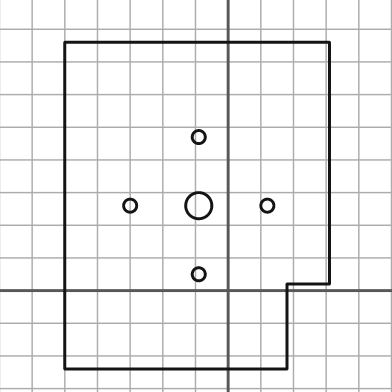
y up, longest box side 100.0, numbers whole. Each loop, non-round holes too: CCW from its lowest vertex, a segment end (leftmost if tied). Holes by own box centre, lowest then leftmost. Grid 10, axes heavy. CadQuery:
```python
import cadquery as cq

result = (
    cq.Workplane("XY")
    .moveTo(-50.0, -24.0)
    .lineTo(18.0, -24.0)
    .lineTo(18.0, 2.0)
    .lineTo(31.0, 2.0)
    .lineTo(31.0, 76.0)
    .lineTo(-50.0, 76.0)
    .close()
    .moveTo(-9.0, 5.0)
    .circle(2.0)
    .moveTo(-30.0, 26.0)
    .circle(2.0)
    .moveTo(-9.0, 26.0)
    .circle(4.0)
    .moveTo(12.0, 26.0)
    .circle(2.0)
    .moveTo(-9.0, 47.0)
    .circle(2.0)
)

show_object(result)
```